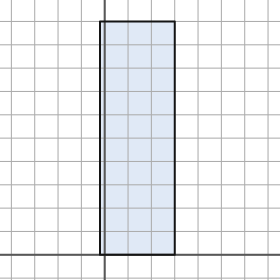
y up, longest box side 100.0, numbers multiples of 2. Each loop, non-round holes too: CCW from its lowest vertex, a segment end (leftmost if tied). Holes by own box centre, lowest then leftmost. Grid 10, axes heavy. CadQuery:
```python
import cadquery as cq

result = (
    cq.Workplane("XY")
    .moveTo(-2.0, 0.0)
    .lineTo(30.0, 0.0)
    .lineTo(30.0, 100.0)
    .lineTo(-2.0, 100.0)
    .close()
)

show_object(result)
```